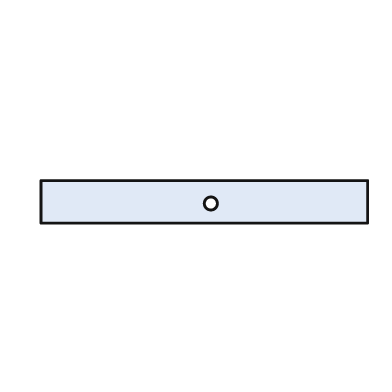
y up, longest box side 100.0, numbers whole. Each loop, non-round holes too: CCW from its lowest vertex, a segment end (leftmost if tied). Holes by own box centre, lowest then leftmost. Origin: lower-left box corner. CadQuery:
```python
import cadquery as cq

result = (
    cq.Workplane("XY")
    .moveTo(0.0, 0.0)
    .lineTo(100.0, 0.0)
    .lineTo(100.0, 13.0)
    .lineTo(0.0, 13.0)
    .close()
    .moveTo(52.0, 6.0)
    .circle(2.0)
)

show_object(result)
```